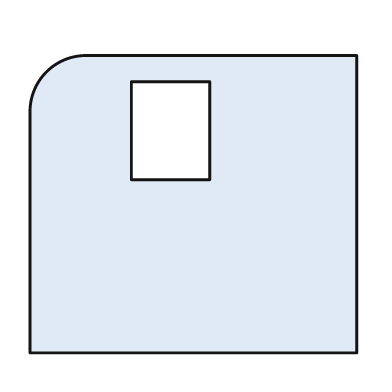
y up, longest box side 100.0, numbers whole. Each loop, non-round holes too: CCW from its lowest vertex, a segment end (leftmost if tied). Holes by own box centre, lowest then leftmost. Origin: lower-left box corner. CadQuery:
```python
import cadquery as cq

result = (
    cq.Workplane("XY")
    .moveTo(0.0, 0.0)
    .lineTo(100.0, 0.0)
    .lineTo(100.0, 91.0)
    .lineTo(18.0, 91.0)
    .threePointArc((5.0, 86.0), (0.0, 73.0))
    .close()
    .moveTo(31.0, 53.0)
    .lineTo(55.0, 53.0)
    .lineTo(55.0, 83.0)
    .lineTo(31.0, 83.0)
    .close()
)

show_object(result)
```